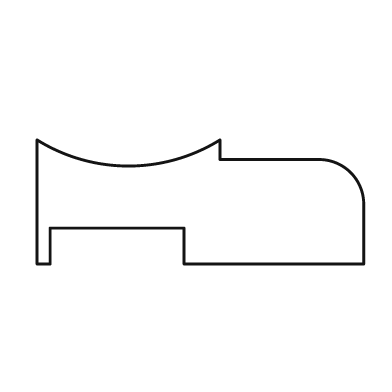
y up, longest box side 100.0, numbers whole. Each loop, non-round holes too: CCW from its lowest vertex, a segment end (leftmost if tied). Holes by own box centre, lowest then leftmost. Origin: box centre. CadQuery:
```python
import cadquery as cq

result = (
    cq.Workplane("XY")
    .moveTo(-50.0, -19.0)
    .lineTo(-46.0, -19.0)
    .lineTo(-46.0, -8.0)
    .lineTo(-5.0, -8.0)
    .lineTo(-5.0, -19.0)
    .lineTo(50.0, -19.0)
    .lineTo(50.0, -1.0)
    .threePointArc((46.0, 9.0), (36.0, 13.0))
    .lineTo(6.0, 13.0)
    .lineTo(6.0, 19.0)
    .threePointArc((-22.0, 11.0), (-50.0, 19.0))
    .close()
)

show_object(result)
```